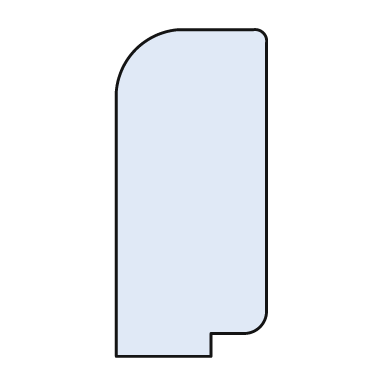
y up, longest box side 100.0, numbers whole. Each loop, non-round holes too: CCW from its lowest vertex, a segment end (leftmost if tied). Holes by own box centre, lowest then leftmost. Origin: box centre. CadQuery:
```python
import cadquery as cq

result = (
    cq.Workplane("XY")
    .moveTo(-23.0, -50.0)
    .lineTo(6.0, -50.0)
    .lineTo(6.0, -43.0)
    .lineTo(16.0, -43.0)
    .threePointArc((21.0, -41.0), (23.0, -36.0))
    .lineTo(23.0, 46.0)
    .threePointArc((22.0, 49.0), (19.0, 50.0))
    .lineTo(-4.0, 50.0)
    .threePointArc((-17.0, 44.0), (-23.0, 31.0))
    .close()
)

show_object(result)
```